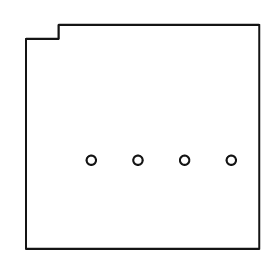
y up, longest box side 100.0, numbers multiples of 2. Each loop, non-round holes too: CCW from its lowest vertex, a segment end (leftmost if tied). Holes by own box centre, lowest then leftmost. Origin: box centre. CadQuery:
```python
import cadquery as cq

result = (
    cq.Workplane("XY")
    .moveTo(-50.0, -48.0)
    .lineTo(50.0, -48.0)
    .lineTo(50.0, 48.0)
    .lineTo(-36.0, 48.0)
    .lineTo(-36.0, 42.0)
    .lineTo(-50.0, 42.0)
    .close()
    .moveTo(-22.0, -10.0)
    .circle(2.0)
    .moveTo(-2.0, -10.0)
    .circle(2.0)
    .moveTo(18.0, -10.0)
    .circle(2.0)
    .moveTo(38.0, -10.0)
    .circle(2.0)
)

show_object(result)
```